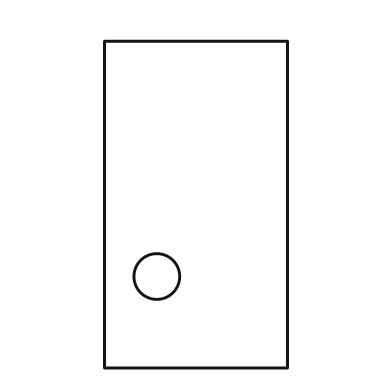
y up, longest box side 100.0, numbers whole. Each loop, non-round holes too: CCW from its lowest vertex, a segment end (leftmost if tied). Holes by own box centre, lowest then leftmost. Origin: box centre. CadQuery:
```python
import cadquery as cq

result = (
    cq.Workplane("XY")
    .moveTo(-28.0, -50.0)
    .lineTo(28.0, -50.0)
    .lineTo(28.0, 50.0)
    .lineTo(-28.0, 50.0)
    .close()
    .moveTo(-12.0, -22.0)
    .circle(7.0)
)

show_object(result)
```